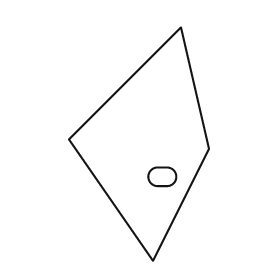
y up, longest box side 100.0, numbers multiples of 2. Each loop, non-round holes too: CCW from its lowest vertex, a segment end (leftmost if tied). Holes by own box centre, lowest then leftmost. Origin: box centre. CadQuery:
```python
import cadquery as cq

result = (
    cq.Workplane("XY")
    .moveTo(6.0, -50.0)
    .lineTo(30.0, -2.0)
    .lineTo(18.0, 50.0)
    .lineTo(-30.0, 2.0)
    .close()
    .moveTo(8.0, -18.0)
    .lineTo(12.0, -18.0)
    .threePointArc((16.0, -14.0), (12.0, -10.0))
    .lineTo(8.0, -10.0)
    .threePointArc((4.0, -14.0), (8.0, -18.0))
    .close()
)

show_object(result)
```